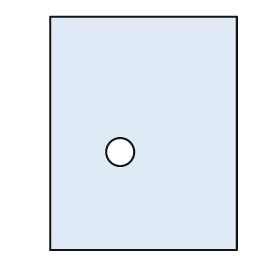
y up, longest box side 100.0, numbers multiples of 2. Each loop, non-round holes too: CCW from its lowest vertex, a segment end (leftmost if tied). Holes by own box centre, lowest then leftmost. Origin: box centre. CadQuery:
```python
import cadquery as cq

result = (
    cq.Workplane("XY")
    .moveTo(-40.0, -50.0)
    .lineTo(40.0, -50.0)
    .lineTo(40.0, 50.0)
    .lineTo(-40.0, 50.0)
    .close()
    .moveTo(-10.0, -8.0)
    .circle(6.0)
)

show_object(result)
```